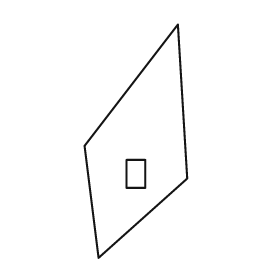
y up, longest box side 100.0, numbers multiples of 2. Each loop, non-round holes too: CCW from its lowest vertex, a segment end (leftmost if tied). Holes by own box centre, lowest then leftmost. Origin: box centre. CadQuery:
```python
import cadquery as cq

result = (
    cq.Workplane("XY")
    .moveTo(-16.0, -50.0)
    .lineTo(22.0, -16.0)
    .lineTo(18.0, 50.0)
    .lineTo(-22.0, -2.0)
    .close()
    .moveTo(-4.0, -20.0)
    .lineTo(4.0, -20.0)
    .lineTo(4.0, -8.0)
    .lineTo(-4.0, -8.0)
    .close()
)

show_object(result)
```